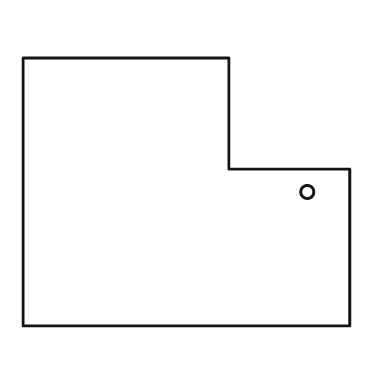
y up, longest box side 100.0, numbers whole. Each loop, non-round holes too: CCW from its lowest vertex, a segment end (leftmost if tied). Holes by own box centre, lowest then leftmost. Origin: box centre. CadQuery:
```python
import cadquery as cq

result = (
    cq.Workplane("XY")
    .moveTo(-50.0, -41.0)
    .lineTo(50.0, -41.0)
    .lineTo(50.0, 7.0)
    .lineTo(13.0, 7.0)
    .lineTo(13.0, 41.0)
    .lineTo(-50.0, 41.0)
    .close()
    .moveTo(37.0, 0.0)
    .circle(2.0)
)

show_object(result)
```